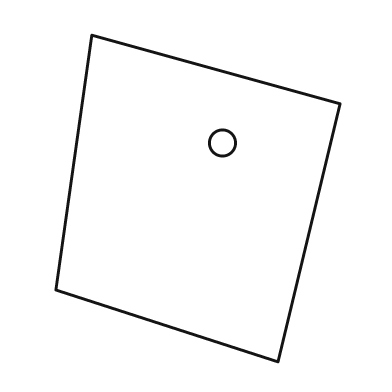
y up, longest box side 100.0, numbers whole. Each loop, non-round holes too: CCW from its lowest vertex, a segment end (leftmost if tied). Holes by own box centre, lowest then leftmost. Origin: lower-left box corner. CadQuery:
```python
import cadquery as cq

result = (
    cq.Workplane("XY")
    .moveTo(68.0, 0.0)
    .lineTo(87.0, 79.0)
    .lineTo(11.0, 100.0)
    .lineTo(0.0, 22.0)
    .close()
    .moveTo(51.0, 67.0)
    .circle(4.0)
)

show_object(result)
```